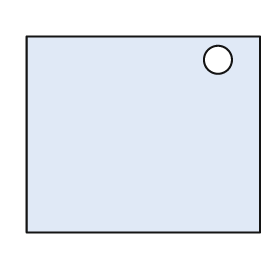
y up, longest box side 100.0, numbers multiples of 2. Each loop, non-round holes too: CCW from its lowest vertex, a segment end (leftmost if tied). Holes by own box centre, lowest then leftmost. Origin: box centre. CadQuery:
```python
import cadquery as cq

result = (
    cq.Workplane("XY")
    .moveTo(-50.0, -42.0)
    .lineTo(50.0, -42.0)
    .lineTo(50.0, 42.0)
    .lineTo(-50.0, 42.0)
    .close()
    .moveTo(32.0, 32.0)
    .circle(6.0)
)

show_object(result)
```